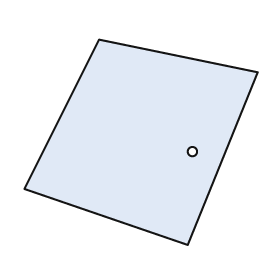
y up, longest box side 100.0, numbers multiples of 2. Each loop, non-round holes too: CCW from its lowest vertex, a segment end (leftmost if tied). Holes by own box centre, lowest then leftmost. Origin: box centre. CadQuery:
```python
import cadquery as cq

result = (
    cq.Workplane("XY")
    .moveTo(20.0, -44.0)
    .lineTo(50.0, 30.0)
    .lineTo(-18.0, 44.0)
    .lineTo(-50.0, -20.0)
    .close()
    .moveTo(22.0, -4.0)
    .circle(2.0)
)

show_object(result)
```